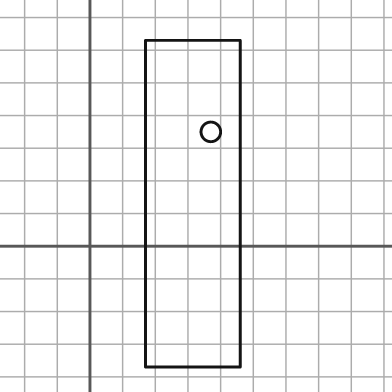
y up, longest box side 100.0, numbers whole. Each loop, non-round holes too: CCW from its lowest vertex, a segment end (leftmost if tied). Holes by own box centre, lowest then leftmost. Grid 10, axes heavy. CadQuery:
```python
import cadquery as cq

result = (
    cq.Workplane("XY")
    .moveTo(17.0, -37.0)
    .lineTo(46.0, -37.0)
    .lineTo(46.0, 63.0)
    .lineTo(17.0, 63.0)
    .close()
    .moveTo(37.0, 35.0)
    .circle(3.0)
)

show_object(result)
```